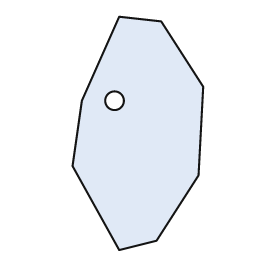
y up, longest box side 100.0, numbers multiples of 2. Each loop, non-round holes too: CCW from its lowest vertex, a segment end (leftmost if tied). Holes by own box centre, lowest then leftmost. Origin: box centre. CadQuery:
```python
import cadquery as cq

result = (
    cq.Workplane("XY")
    .moveTo(-8.0, -50.0)
    .lineTo(8.0, -46.0)
    .lineTo(26.0, -18.0)
    .lineTo(28.0, 20.0)
    .lineTo(10.0, 48.0)
    .lineTo(-8.0, 50.0)
    .lineTo(-24.0, 14.0)
    .lineTo(-28.0, -14.0)
    .close()
    .moveTo(-10.0, 14.0)
    .circle(4.0)
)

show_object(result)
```